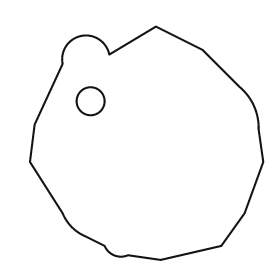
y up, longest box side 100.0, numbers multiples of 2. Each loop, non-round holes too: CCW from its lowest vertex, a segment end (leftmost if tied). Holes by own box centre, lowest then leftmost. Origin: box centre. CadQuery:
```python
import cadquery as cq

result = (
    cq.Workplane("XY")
    .moveTo(6.0, -50.0)
    .lineTo(32.0, -44.0)
    .lineTo(42.0, -30.0)
    .lineTo(50.0, -8.0)
    .lineTo(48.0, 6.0)
    .threePointArc((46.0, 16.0), (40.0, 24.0))
    .lineTo(24.0, 40.0)
    .lineTo(4.0, 50.0)
    .lineTo(-16.0, 38.0)
    .threePointArc((-28.0, 46.0), (-36.0, 34.0))
    .lineTo(-48.0, 8.0)
    .lineTo(-50.0, -8.0)
    .lineTo(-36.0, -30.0)
    .threePointArc((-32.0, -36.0), (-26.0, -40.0))
    .lineTo(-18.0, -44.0)
    .threePointArc((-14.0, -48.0), (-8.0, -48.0))
    .close()
    .moveTo(-24.0, 18.0)
    .circle(6.0)
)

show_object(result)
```